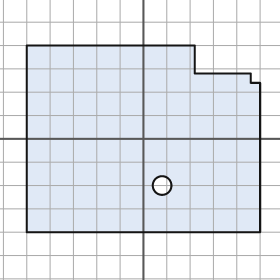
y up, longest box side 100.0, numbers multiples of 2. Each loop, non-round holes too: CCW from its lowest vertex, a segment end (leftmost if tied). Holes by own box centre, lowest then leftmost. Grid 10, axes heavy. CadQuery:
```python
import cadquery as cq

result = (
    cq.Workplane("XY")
    .moveTo(-50.0, -40.0)
    .lineTo(50.0, -40.0)
    .lineTo(50.0, 24.0)
    .lineTo(46.0, 24.0)
    .lineTo(46.0, 28.0)
    .lineTo(22.0, 28.0)
    .lineTo(22.0, 40.0)
    .lineTo(-50.0, 40.0)
    .close()
    .moveTo(8.0, -20.0)
    .circle(4.0)
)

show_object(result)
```